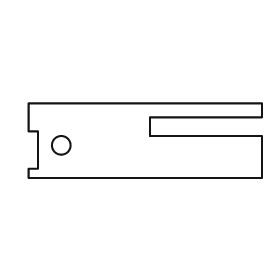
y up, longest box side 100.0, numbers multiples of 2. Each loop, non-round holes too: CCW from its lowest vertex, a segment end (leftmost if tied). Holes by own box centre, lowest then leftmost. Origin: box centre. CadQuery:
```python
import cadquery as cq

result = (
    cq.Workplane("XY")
    .moveTo(-50.0, -16.0)
    .lineTo(50.0, -16.0)
    .lineTo(50.0, 2.0)
    .lineTo(2.0, 2.0)
    .lineTo(2.0, 10.0)
    .lineTo(50.0, 10.0)
    .lineTo(50.0, 16.0)
    .lineTo(-50.0, 16.0)
    .lineTo(-50.0, 4.0)
    .lineTo(-46.0, 4.0)
    .lineTo(-46.0, -12.0)
    .lineTo(-50.0, -12.0)
    .close()
    .moveTo(-36.0, -2.0)
    .circle(4.0)
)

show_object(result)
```